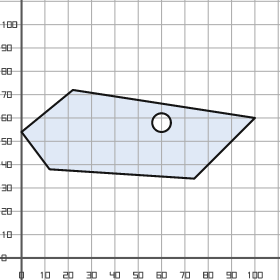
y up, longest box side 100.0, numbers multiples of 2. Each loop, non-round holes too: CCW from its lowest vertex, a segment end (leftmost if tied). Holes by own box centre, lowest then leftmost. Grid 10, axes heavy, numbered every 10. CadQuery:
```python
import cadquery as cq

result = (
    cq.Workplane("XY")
    .moveTo(74.0, 34.0)
    .lineTo(100.0, 60.0)
    .lineTo(22.0, 72.0)
    .lineTo(0.0, 54.0)
    .lineTo(12.0, 38.0)
    .close()
    .moveTo(60.0, 58.0)
    .circle(4.0)
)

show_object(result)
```